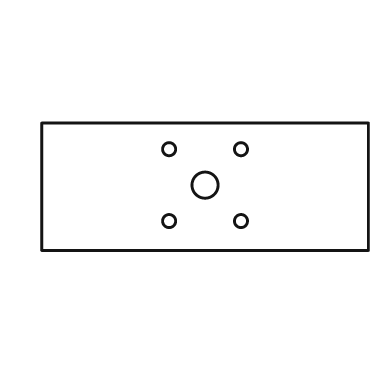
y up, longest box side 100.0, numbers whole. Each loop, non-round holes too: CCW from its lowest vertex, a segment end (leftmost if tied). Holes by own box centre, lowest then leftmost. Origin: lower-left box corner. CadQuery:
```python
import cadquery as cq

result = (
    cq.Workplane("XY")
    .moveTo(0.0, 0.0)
    .lineTo(100.0, 0.0)
    .lineTo(100.0, 39.0)
    .lineTo(0.0, 39.0)
    .close()
    .moveTo(39.0, 9.0)
    .circle(2.0)
    .moveTo(61.0, 9.0)
    .circle(2.0)
    .moveTo(50.0, 20.0)
    .circle(4.0)
    .moveTo(39.0, 31.0)
    .circle(2.0)
    .moveTo(61.0, 31.0)
    .circle(2.0)
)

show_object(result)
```